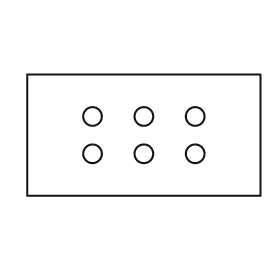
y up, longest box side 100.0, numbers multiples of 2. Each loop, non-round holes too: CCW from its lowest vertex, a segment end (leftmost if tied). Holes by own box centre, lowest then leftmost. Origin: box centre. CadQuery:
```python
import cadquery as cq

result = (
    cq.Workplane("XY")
    .moveTo(-50.0, -26.0)
    .lineTo(50.0, -26.0)
    .lineTo(50.0, 26.0)
    .lineTo(-50.0, 26.0)
    .close()
    .moveTo(-22.0, -8.0)
    .circle(4.0)
    .moveTo(0.0, -8.0)
    .circle(4.0)
    .moveTo(22.0, -8.0)
    .circle(4.0)
    .moveTo(-22.0, 8.0)
    .circle(4.0)
    .moveTo(0.0, 8.0)
    .circle(4.0)
    .moveTo(22.0, 8.0)
    .circle(4.0)
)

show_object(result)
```